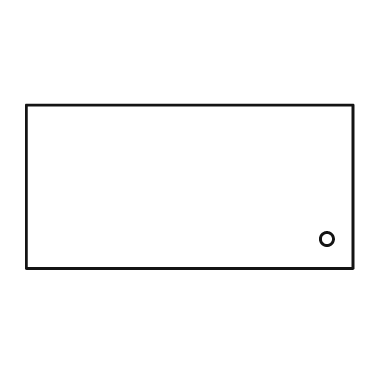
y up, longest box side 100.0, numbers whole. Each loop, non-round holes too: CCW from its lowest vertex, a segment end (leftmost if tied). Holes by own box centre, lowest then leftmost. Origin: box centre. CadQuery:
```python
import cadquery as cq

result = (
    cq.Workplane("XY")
    .moveTo(-50.0, -25.0)
    .lineTo(50.0, -25.0)
    .lineTo(50.0, 25.0)
    .lineTo(-50.0, 25.0)
    .close()
    .moveTo(42.0, -16.0)
    .circle(2.0)
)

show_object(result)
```